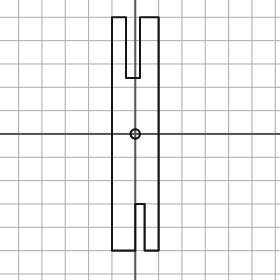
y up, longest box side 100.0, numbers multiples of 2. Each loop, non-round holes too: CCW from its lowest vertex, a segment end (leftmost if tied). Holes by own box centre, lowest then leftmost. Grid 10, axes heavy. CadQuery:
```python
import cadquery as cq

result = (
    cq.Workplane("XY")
    .moveTo(-10.0, -50.0)
    .lineTo(0.0, -50.0)
    .lineTo(0.0, -30.0)
    .lineTo(4.0, -30.0)
    .lineTo(4.0, -50.0)
    .lineTo(10.0, -50.0)
    .lineTo(10.0, 50.0)
    .lineTo(2.0, 50.0)
    .lineTo(2.0, 24.0)
    .lineTo(-4.0, 24.0)
    .lineTo(-4.0, 50.0)
    .lineTo(-10.0, 50.0)
    .close()
    .moveTo(0.0, 0.0)
    .circle(2.0)
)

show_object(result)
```